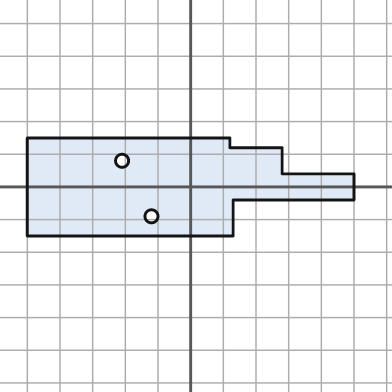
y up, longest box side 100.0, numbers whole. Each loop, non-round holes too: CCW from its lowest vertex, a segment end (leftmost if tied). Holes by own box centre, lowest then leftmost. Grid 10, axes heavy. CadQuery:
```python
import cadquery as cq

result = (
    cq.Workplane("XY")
    .moveTo(-50.0, -15.0)
    .lineTo(13.0, -15.0)
    .lineTo(13.0, -4.0)
    .lineTo(50.0, -4.0)
    .lineTo(50.0, 4.0)
    .lineTo(28.0, 4.0)
    .lineTo(28.0, 12.0)
    .lineTo(12.0, 12.0)
    .lineTo(12.0, 15.0)
    .lineTo(-50.0, 15.0)
    .close()
    .moveTo(-12.0, -9.0)
    .circle(2.0)
    .moveTo(-21.0, 8.0)
    .circle(2.0)
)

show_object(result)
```